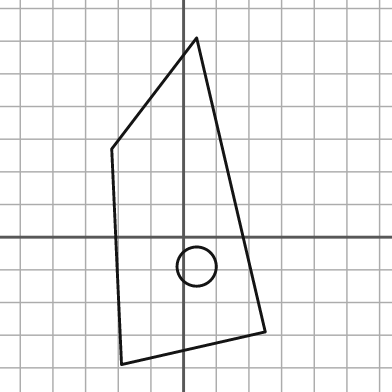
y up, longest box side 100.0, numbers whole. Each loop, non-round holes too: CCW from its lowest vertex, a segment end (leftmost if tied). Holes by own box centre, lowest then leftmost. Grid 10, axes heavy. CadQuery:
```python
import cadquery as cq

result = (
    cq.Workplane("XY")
    .moveTo(-19.0, -39.0)
    .lineTo(25.0, -29.0)
    .lineTo(4.0, 61.0)
    .lineTo(-22.0, 27.0)
    .close()
    .moveTo(4.0, -9.0)
    .circle(6.0)
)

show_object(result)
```